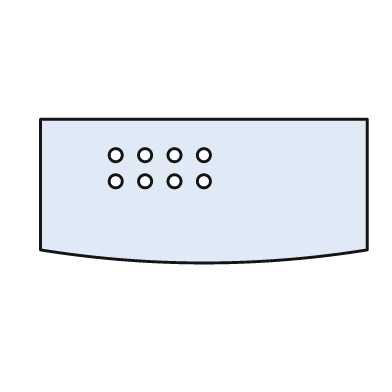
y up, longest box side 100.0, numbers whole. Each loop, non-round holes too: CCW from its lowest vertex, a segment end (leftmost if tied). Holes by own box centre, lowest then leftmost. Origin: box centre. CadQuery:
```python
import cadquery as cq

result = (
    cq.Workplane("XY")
    .moveTo(-50.0, -18.0)
    .threePointArc((0.0, -22.0), (50.0, -18.0))
    .lineTo(50.0, 22.0)
    .lineTo(-50.0, 22.0)
    .close()
    .moveTo(-27.0, 3.0)
    .circle(2.0)
    .moveTo(-18.0, 3.0)
    .circle(2.0)
    .moveTo(-9.0, 3.0)
    .circle(2.0)
    .moveTo(0.0, 3.0)
    .circle(2.0)
    .moveTo(-27.0, 11.0)
    .circle(2.0)
    .moveTo(-18.0, 11.0)
    .circle(2.0)
    .moveTo(-9.0, 11.0)
    .circle(2.0)
    .moveTo(0.0, 11.0)
    .circle(2.0)
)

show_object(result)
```